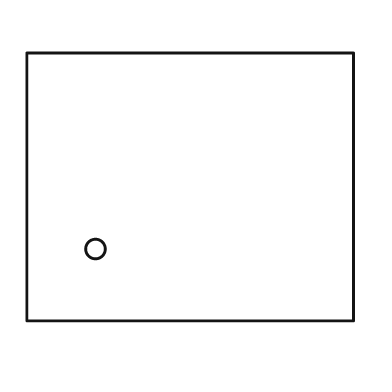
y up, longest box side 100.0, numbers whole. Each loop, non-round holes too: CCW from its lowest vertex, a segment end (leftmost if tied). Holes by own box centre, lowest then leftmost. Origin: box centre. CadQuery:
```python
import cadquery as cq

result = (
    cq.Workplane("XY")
    .moveTo(-50.0, -41.0)
    .lineTo(50.0, -41.0)
    .lineTo(50.0, 41.0)
    .lineTo(-50.0, 41.0)
    .close()
    .moveTo(-29.0, -19.0)
    .circle(3.0)
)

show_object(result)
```